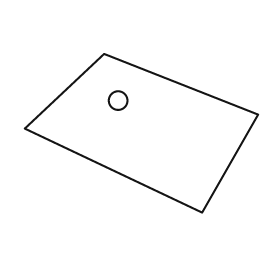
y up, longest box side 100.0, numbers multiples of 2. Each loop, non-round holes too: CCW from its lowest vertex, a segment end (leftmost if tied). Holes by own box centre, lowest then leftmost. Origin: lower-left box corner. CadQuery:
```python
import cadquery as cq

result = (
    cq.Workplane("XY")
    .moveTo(76.0, 0.0)
    .lineTo(100.0, 42.0)
    .lineTo(34.0, 68.0)
    .lineTo(0.0, 36.0)
    .close()
    .moveTo(40.0, 48.0)
    .circle(4.0)
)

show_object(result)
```